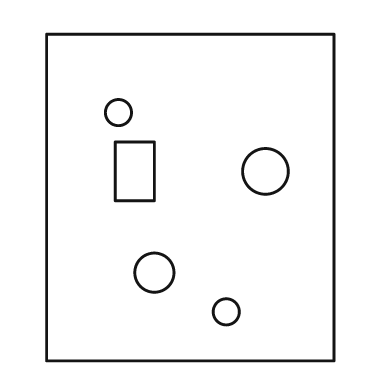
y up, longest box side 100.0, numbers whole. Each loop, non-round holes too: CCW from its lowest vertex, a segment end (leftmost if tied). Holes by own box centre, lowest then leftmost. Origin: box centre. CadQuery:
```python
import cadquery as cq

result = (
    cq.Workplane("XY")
    .moveTo(-44.0, -50.0)
    .lineTo(44.0, -50.0)
    .lineTo(44.0, 50.0)
    .lineTo(-44.0, 50.0)
    .close()
    .moveTo(11.0, -35.0)
    .circle(4.0)
    .moveTo(-11.0, -23.0)
    .circle(6.0)
    .moveTo(-23.0, -1.0)
    .lineTo(-11.0, -1.0)
    .lineTo(-11.0, 17.0)
    .lineTo(-23.0, 17.0)
    .close()
    .moveTo(23.0, 8.0)
    .circle(7.0)
    .moveTo(-22.0, 26.0)
    .circle(4.0)
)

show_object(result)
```